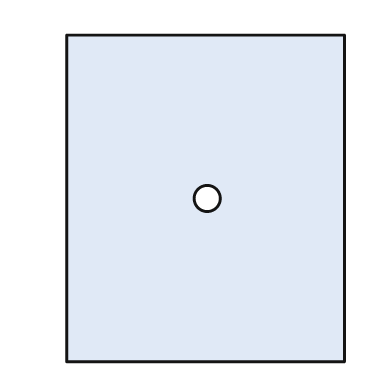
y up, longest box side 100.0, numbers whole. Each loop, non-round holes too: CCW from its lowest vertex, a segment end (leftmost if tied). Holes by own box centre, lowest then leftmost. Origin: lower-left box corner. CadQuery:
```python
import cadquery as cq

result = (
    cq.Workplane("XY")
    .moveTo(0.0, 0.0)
    .lineTo(85.0, 0.0)
    .lineTo(85.0, 100.0)
    .lineTo(0.0, 100.0)
    .close()
    .moveTo(43.0, 50.0)
    .circle(4.0)
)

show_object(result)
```